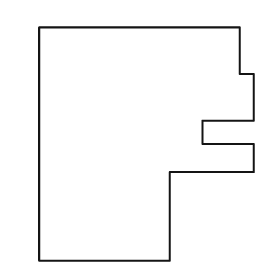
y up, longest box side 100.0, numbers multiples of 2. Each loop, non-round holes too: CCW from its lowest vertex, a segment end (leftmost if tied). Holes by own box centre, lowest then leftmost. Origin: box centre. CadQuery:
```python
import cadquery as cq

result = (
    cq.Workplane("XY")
    .moveTo(-46.0, -50.0)
    .lineTo(10.0, -50.0)
    .lineTo(10.0, -12.0)
    .lineTo(46.0, -12.0)
    .lineTo(46.0, 0.0)
    .lineTo(24.0, 0.0)
    .lineTo(24.0, 10.0)
    .lineTo(46.0, 10.0)
    .lineTo(46.0, 30.0)
    .lineTo(40.0, 30.0)
    .lineTo(40.0, 50.0)
    .lineTo(-46.0, 50.0)
    .close()
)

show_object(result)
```